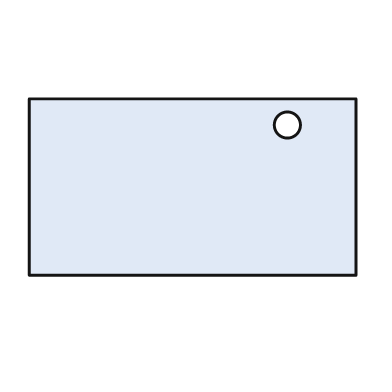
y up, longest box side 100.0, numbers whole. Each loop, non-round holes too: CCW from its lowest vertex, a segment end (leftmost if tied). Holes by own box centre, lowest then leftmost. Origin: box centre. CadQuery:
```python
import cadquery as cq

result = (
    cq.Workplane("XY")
    .moveTo(-50.0, -27.0)
    .lineTo(50.0, -27.0)
    .lineTo(50.0, 27.0)
    .lineTo(-50.0, 27.0)
    .close()
    .moveTo(29.0, 19.0)
    .circle(4.0)
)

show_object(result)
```